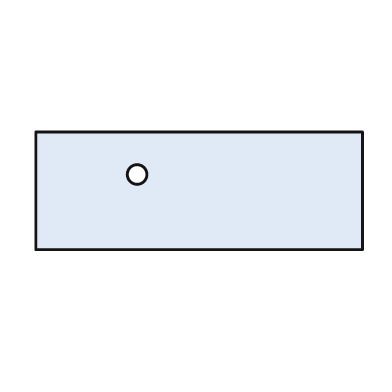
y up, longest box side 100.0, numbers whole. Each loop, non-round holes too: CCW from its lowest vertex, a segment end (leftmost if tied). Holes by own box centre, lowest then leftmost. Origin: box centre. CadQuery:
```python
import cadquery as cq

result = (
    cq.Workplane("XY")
    .moveTo(-50.0, -18.0)
    .lineTo(50.0, -18.0)
    .lineTo(50.0, 18.0)
    .lineTo(-50.0, 18.0)
    .close()
    .moveTo(-19.0, 5.0)
    .circle(3.0)
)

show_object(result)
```